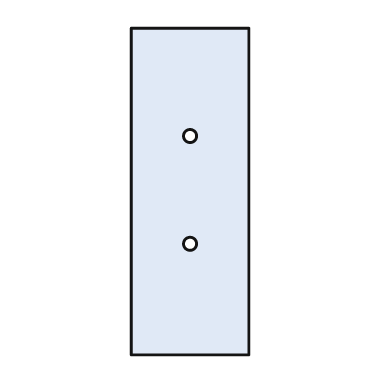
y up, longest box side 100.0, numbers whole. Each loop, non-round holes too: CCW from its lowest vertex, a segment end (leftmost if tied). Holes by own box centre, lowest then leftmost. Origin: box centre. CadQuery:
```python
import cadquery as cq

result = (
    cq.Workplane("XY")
    .moveTo(-18.0, -50.0)
    .lineTo(18.0, -50.0)
    .lineTo(18.0, 50.0)
    .lineTo(-18.0, 50.0)
    .close()
    .moveTo(0.0, -16.0)
    .circle(2.0)
    .moveTo(0.0, 17.0)
    .circle(2.0)
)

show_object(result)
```